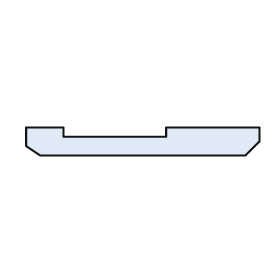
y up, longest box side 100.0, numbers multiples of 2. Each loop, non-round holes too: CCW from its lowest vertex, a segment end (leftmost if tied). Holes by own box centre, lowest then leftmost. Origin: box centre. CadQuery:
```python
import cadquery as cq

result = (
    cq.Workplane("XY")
    .moveTo(-44.0, -6.0)
    .lineTo(44.0, -6.0)
    .lineTo(50.0, 0.0)
    .lineTo(50.0, 6.0)
    .lineTo(10.0, 6.0)
    .lineTo(10.0, 2.0)
    .lineTo(-34.0, 2.0)
    .lineTo(-34.0, 6.0)
    .lineTo(-50.0, 6.0)
    .lineTo(-50.0, -2.0)
    .close()
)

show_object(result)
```